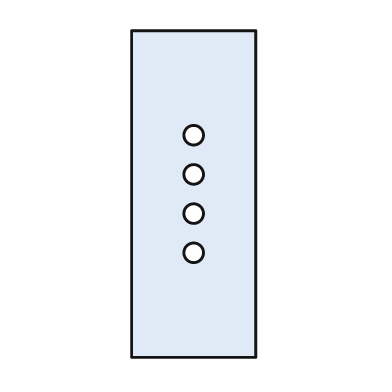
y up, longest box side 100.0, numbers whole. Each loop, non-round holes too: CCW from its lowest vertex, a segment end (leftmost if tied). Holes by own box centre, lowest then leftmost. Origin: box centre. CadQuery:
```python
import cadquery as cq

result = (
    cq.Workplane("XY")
    .moveTo(-19.0, -50.0)
    .lineTo(19.0, -50.0)
    .lineTo(19.0, 50.0)
    .lineTo(-19.0, 50.0)
    .close()
    .moveTo(0.0, -18.0)
    .circle(3.0)
    .moveTo(0.0, -6.0)
    .circle(3.0)
    .moveTo(0.0, 6.0)
    .circle(3.0)
    .moveTo(0.0, 18.0)
    .circle(3.0)
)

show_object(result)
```